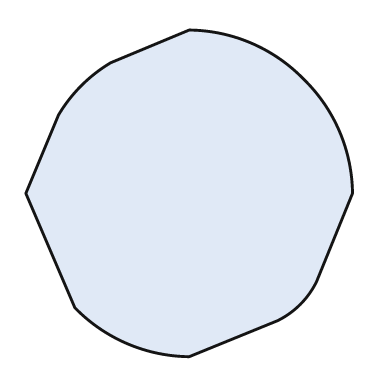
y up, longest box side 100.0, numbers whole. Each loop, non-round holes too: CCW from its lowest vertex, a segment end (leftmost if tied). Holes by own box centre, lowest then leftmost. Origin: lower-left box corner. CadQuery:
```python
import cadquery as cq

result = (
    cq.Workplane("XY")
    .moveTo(50.0, 0.0)
    .lineTo(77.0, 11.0)
    .threePointArc((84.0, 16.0), (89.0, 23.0))
    .lineTo(100.0, 50.0)
    .threePointArc((96.0, 69.0), (85.0, 85.0))
    .threePointArc((69.0, 96.0), (50.0, 100.0))
    .lineTo(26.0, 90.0)
    .threePointArc((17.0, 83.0), (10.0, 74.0))
    .lineTo(0.0, 50.0)
    .lineTo(15.0, 15.0)
    .threePointArc((31.0, 4.0), (50.0, 0.0))
    .close()
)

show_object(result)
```